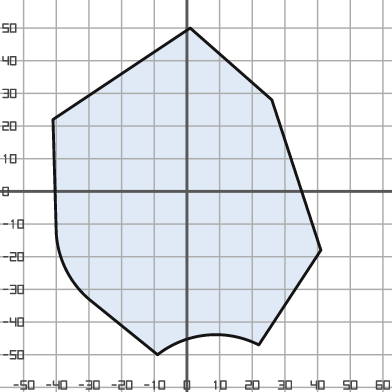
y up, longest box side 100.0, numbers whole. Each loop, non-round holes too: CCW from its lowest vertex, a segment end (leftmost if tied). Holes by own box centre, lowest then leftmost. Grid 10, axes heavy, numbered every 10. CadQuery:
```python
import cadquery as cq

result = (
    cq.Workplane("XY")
    .moveTo(-9.0, -50.0)
    .threePointArc((6.0, -44.0), (22.0, -47.0))
    .lineTo(41.0, -18.0)
    .lineTo(26.0, 28.0)
    .lineTo(1.0, 50.0)
    .lineTo(-41.0, 22.0)
    .lineTo(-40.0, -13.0)
    .threePointArc((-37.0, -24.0), (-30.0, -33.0))
    .close()
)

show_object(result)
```